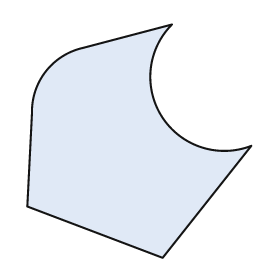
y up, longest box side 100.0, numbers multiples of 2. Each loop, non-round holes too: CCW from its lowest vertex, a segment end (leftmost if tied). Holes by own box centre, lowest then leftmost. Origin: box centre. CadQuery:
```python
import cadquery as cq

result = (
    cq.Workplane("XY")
    .moveTo(10.0, -50.0)
    .lineTo(48.0, -2.0)
    .threePointArc((10.0, 10.0), (14.0, 50.0))
    .lineTo(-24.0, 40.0)
    .threePointArc((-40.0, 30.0), (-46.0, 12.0))
    .lineTo(-48.0, -28.0)
    .close()
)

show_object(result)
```